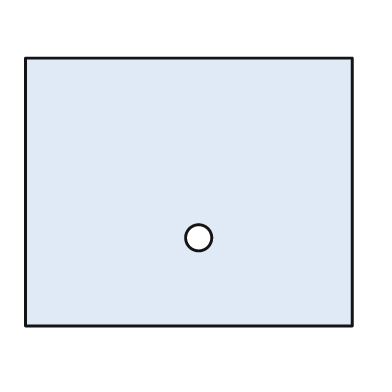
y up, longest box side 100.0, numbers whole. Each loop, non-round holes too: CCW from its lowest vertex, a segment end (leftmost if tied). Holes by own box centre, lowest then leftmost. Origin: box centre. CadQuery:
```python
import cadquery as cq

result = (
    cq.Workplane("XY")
    .moveTo(-50.0, -41.0)
    .lineTo(50.0, -41.0)
    .lineTo(50.0, 41.0)
    .lineTo(-50.0, 41.0)
    .close()
    .moveTo(3.0, -14.0)
    .circle(4.0)
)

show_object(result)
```